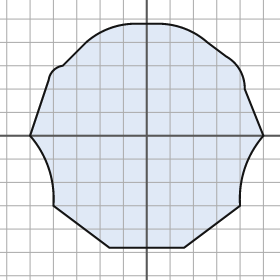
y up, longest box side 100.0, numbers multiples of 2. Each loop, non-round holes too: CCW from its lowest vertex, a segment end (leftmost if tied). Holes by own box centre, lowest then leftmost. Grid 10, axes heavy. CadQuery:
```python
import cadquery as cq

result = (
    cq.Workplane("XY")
    .moveTo(-16.0, -48.0)
    .lineTo(16.0, -48.0)
    .lineTo(40.0, -30.0)
    .threePointArc((42.0, -14.0), (50.0, 0.0))
    .lineTo(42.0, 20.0)
    .threePointArc((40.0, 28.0), (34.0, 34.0))
    .lineTo(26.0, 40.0)
    .threePointArc((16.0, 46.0), (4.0, 48.0))
    .lineTo(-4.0, 48.0)
    .threePointArc((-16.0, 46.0), (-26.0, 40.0))
    .lineTo(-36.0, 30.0)
    .threePointArc((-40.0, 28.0), (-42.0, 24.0))
    .lineTo(-50.0, 0.0)
    .threePointArc((-42.0, -14.0), (-40.0, -30.0))
    .close()
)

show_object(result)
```